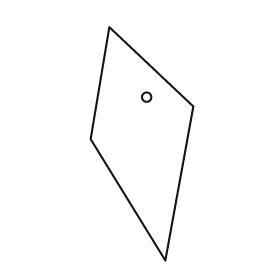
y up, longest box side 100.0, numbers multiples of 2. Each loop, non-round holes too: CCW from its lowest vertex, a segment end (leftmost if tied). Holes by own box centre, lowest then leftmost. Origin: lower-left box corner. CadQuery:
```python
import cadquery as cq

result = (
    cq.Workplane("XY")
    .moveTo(32.0, 0.0)
    .lineTo(44.0, 66.0)
    .lineTo(8.0, 100.0)
    .lineTo(0.0, 52.0)
    .close()
    .moveTo(24.0, 70.0)
    .circle(2.0)
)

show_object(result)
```